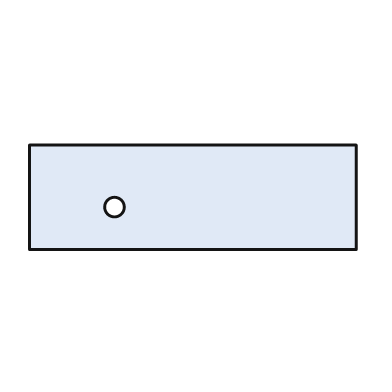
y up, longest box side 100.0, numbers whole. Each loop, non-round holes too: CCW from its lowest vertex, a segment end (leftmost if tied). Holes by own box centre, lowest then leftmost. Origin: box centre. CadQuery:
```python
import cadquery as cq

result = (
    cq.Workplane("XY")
    .moveTo(-50.0, -16.0)
    .lineTo(50.0, -16.0)
    .lineTo(50.0, 16.0)
    .lineTo(-50.0, 16.0)
    .close()
    .moveTo(-24.0, -3.0)
    .circle(3.0)
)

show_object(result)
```